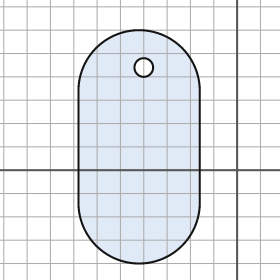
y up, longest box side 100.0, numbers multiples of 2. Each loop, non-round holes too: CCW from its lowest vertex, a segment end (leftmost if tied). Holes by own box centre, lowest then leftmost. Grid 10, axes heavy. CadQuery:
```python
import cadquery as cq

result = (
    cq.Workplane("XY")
    .moveTo(-68.0, -14.0)
    .threePointArc((-42.0, -40.0), (-16.0, -14.0))
    .lineTo(-16.0, 34.0)
    .threePointArc((-42.0, 60.0), (-68.0, 34.0))
    .close()
    .moveTo(-40.0, 44.0)
    .circle(4.0)
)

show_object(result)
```